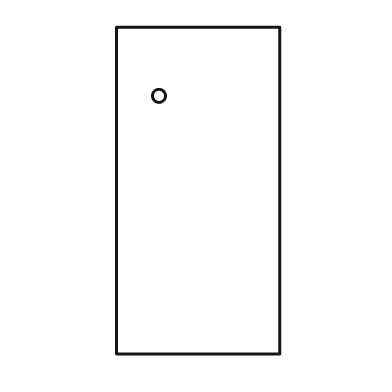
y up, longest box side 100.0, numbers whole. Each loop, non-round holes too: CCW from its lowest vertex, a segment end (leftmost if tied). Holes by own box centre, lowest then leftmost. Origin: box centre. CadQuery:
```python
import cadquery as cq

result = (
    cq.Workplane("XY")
    .moveTo(-25.0, -50.0)
    .lineTo(25.0, -50.0)
    .lineTo(25.0, 50.0)
    .lineTo(-25.0, 50.0)
    .close()
    .moveTo(-12.0, 29.0)
    .circle(2.0)
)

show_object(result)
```